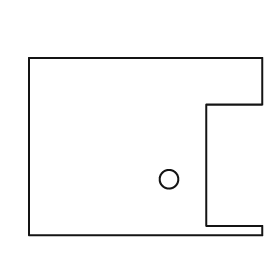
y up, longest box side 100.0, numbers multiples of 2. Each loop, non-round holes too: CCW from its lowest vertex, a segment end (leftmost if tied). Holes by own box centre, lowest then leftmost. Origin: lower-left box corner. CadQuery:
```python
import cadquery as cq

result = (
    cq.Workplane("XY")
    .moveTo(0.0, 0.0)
    .lineTo(100.0, 0.0)
    .lineTo(100.0, 4.0)
    .lineTo(76.0, 4.0)
    .lineTo(76.0, 56.0)
    .lineTo(100.0, 56.0)
    .lineTo(100.0, 76.0)
    .lineTo(0.0, 76.0)
    .close()
    .moveTo(60.0, 24.0)
    .circle(4.0)
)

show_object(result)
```